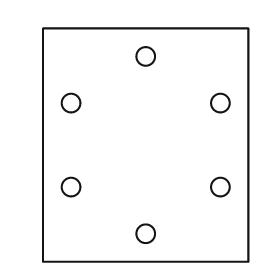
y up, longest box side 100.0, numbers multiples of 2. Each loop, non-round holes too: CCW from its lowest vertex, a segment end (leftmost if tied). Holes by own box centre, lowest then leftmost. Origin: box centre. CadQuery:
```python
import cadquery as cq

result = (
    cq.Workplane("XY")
    .moveTo(-44.0, -50.0)
    .lineTo(44.0, -50.0)
    .lineTo(44.0, 50.0)
    .lineTo(-44.0, 50.0)
    .close()
    .moveTo(0.0, -38.0)
    .circle(4.0)
    .moveTo(-32.0, -18.0)
    .circle(4.0)
    .moveTo(32.0, -18.0)
    .circle(4.0)
    .moveTo(-32.0, 18.0)
    .circle(4.0)
    .moveTo(32.0, 18.0)
    .circle(4.0)
    .moveTo(0.0, 38.0)
    .circle(4.0)
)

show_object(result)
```